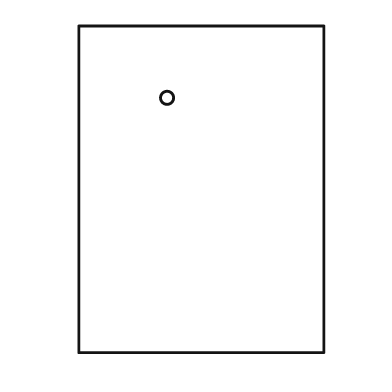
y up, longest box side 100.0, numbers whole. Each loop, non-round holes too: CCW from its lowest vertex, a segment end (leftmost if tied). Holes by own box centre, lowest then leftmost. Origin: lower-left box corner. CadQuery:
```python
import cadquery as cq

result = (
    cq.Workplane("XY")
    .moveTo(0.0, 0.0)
    .lineTo(75.0, 0.0)
    .lineTo(75.0, 100.0)
    .lineTo(0.0, 100.0)
    .close()
    .moveTo(27.0, 78.0)
    .circle(2.0)
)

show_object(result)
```